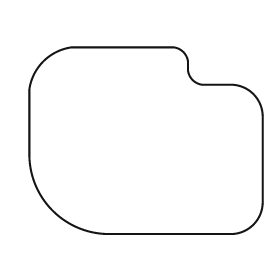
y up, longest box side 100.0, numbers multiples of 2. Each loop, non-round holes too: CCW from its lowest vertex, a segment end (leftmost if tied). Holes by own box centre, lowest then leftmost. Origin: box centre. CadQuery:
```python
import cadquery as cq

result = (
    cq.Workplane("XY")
    .moveTo(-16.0, -40.0)
    .lineTo(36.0, -40.0)
    .threePointArc((46.0, -36.0), (50.0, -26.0))
    .lineTo(50.0, 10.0)
    .threePointArc((46.0, 20.0), (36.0, 24.0))
    .lineTo(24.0, 24.0)
    .threePointArc((20.0, 26.0), (18.0, 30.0))
    .lineTo(18.0, 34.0)
    .threePointArc((16.0, 38.0), (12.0, 40.0))
    .lineTo(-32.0, 40.0)
    .threePointArc((-44.0, 34.0), (-50.0, 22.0))
    .lineTo(-50.0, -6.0)
    .threePointArc((-40.0, -30.0), (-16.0, -40.0))
    .close()
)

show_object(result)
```